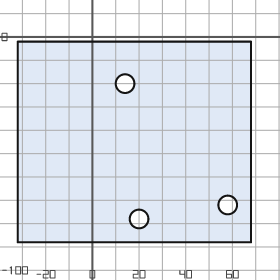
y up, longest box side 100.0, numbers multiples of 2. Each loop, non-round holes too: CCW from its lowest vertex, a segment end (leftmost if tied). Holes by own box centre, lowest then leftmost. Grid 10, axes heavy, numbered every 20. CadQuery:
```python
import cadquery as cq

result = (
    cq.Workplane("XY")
    .moveTo(-32.0, -88.0)
    .lineTo(68.0, -88.0)
    .lineTo(68.0, -2.0)
    .lineTo(-32.0, -2.0)
    .close()
    .moveTo(20.0, -78.0)
    .circle(4.0)
    .moveTo(58.0, -72.0)
    .circle(4.0)
    .moveTo(14.0, -20.0)
    .circle(4.0)
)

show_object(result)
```